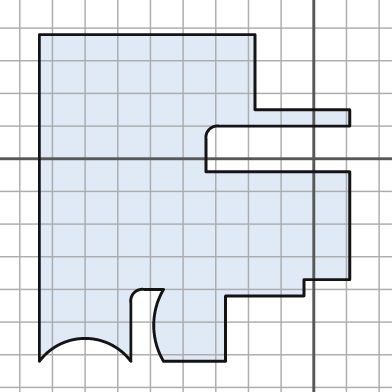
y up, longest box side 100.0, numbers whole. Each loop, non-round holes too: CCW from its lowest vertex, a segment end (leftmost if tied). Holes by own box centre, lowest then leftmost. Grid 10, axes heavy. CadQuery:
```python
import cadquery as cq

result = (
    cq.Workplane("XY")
    .moveTo(-84.0, -62.0)
    .threePointArc((-70.0, -55.0), (-56.0, -62.0))
    .lineTo(-56.0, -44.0)
    .threePointArc((-55.0, -41.0), (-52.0, -40.0))
    .lineTo(-46.0, -40.0)
    .threePointArc((-49.0, -51.0), (-46.0, -62.0))
    .lineTo(-27.0, -62.0)
    .lineTo(-27.0, -42.0)
    .lineTo(-3.0, -42.0)
    .lineTo(-3.0, -37.0)
    .lineTo(11.0, -37.0)
    .lineTo(11.0, -4.0)
    .lineTo(-33.0, -4.0)
    .lineTo(-33.0, 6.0)
    .threePointArc((-32.0, 9.0), (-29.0, 10.0))
    .lineTo(11.0, 10.0)
    .lineTo(11.0, 15.0)
    .lineTo(-18.0, 15.0)
    .lineTo(-18.0, 38.0)
    .lineTo(-84.0, 38.0)
    .close()
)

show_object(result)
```